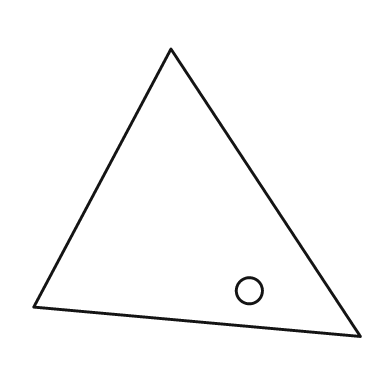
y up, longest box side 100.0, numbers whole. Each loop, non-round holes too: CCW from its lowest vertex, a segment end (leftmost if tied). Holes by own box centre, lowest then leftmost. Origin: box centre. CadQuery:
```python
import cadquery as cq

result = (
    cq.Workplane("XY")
    .moveTo(50.0, -44.0)
    .lineTo(-8.0, 44.0)
    .lineTo(-50.0, -35.0)
    .close()
    .moveTo(16.0, -30.0)
    .circle(4.0)
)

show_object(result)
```